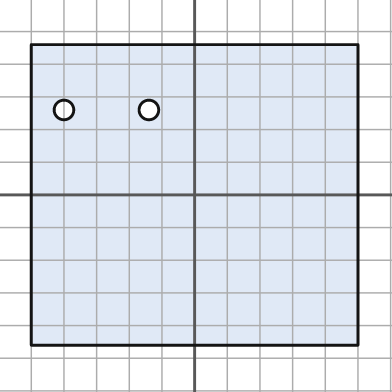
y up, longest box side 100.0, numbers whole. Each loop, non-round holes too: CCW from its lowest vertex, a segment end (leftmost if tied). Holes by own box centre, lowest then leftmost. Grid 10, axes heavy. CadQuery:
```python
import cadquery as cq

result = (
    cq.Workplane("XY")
    .moveTo(-50.0, -46.0)
    .lineTo(50.0, -46.0)
    .lineTo(50.0, 46.0)
    .lineTo(-50.0, 46.0)
    .close()
    .moveTo(-40.0, 26.0)
    .circle(3.0)
    .moveTo(-14.0, 26.0)
    .circle(3.0)
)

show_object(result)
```